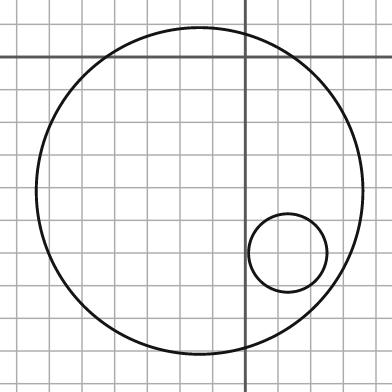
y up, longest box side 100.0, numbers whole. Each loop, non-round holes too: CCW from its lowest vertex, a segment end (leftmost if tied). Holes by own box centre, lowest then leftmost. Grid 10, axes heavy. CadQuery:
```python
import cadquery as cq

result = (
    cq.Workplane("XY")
    .moveTo(-14.0, -41.0)
    .circle(50.0)
    .moveTo(13.0, -60.0)
    .circle(12.0)
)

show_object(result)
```